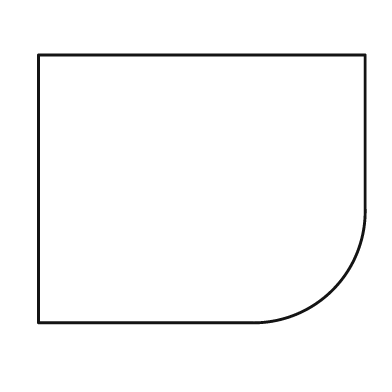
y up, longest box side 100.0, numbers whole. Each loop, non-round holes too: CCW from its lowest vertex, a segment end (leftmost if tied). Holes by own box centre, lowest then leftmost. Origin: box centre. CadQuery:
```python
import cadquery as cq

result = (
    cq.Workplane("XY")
    .moveTo(-50.0, -41.0)
    .lineTo(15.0, -41.0)
    .threePointArc((40.0, -31.0), (50.0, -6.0))
    .lineTo(50.0, 41.0)
    .lineTo(-50.0, 41.0)
    .close()
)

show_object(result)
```